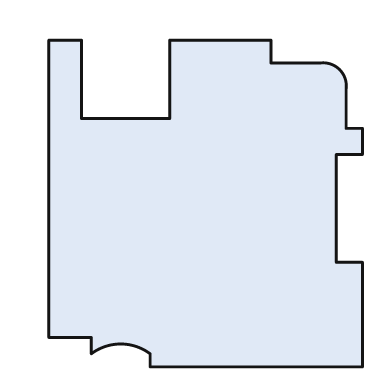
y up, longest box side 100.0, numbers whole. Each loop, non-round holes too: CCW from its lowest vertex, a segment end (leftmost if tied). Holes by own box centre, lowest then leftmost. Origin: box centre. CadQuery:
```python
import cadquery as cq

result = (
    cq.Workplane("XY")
    .moveTo(-17.0, -50.0)
    .lineTo(48.0, -50.0)
    .lineTo(48.0, -18.0)
    .lineTo(40.0, -18.0)
    .lineTo(40.0, 15.0)
    .lineTo(48.0, 15.0)
    .lineTo(48.0, 23.0)
    .lineTo(43.0, 23.0)
    .lineTo(43.0, 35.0)
    .threePointArc((41.0, 41.0), (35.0, 43.0))
    .lineTo(20.0, 43.0)
    .lineTo(20.0, 50.0)
    .lineTo(-11.0, 50.0)
    .lineTo(-11.0, 26.0)
    .lineTo(-38.0, 26.0)
    .lineTo(-38.0, 50.0)
    .lineTo(-48.0, 50.0)
    .lineTo(-48.0, -41.0)
    .lineTo(-35.0, -41.0)
    .lineTo(-35.0, -46.0)
    .threePointArc((-26.0, -43.0), (-17.0, -46.0))
    .close()
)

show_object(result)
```